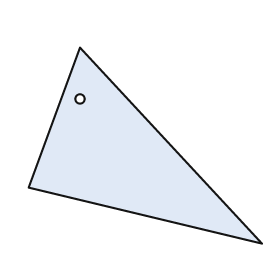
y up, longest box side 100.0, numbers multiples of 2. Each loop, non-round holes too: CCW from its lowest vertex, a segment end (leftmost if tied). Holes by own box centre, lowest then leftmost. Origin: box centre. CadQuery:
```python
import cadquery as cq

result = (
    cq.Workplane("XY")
    .moveTo(50.0, -42.0)
    .lineTo(-28.0, 42.0)
    .lineTo(-50.0, -18.0)
    .close()
    .moveTo(-28.0, 20.0)
    .circle(2.0)
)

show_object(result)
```